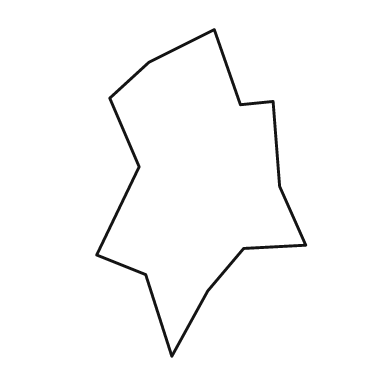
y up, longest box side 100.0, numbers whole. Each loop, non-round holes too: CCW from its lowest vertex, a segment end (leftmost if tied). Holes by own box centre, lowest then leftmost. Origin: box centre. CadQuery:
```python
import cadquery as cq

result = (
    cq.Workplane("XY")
    .moveTo(-9.0, -50.0)
    .lineTo(2.0, -30.0)
    .lineTo(13.0, -17.0)
    .lineTo(32.0, -16.0)
    .lineTo(24.0, 2.0)
    .lineTo(22.0, 28.0)
    .lineTo(12.0, 27.0)
    .lineTo(4.0, 50.0)
    .lineTo(-16.0, 40.0)
    .lineTo(-28.0, 29.0)
    .lineTo(-19.0, 8.0)
    .lineTo(-32.0, -19.0)
    .lineTo(-17.0, -25.0)
    .close()
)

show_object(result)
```